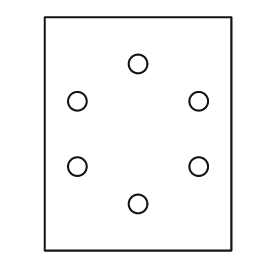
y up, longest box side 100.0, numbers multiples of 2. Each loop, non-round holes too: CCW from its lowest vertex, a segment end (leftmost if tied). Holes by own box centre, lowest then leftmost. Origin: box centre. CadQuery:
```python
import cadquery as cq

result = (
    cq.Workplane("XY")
    .moveTo(-40.0, -50.0)
    .lineTo(40.0, -50.0)
    .lineTo(40.0, 50.0)
    .lineTo(-40.0, 50.0)
    .close()
    .moveTo(0.0, -30.0)
    .circle(4.0)
    .moveTo(-26.0, -14.0)
    .circle(4.0)
    .moveTo(26.0, -14.0)
    .circle(4.0)
    .moveTo(-26.0, 14.0)
    .circle(4.0)
    .moveTo(26.0, 14.0)
    .circle(4.0)
    .moveTo(0.0, 30.0)
    .circle(4.0)
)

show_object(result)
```